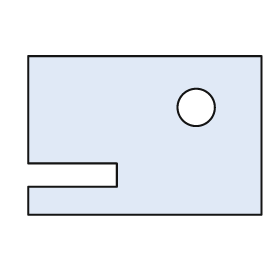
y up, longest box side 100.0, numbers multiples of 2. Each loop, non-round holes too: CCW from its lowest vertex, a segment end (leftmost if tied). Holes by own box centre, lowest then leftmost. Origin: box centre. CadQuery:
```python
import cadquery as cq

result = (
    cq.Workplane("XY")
    .moveTo(-50.0, -34.0)
    .lineTo(50.0, -34.0)
    .lineTo(50.0, 34.0)
    .lineTo(-50.0, 34.0)
    .lineTo(-50.0, -12.0)
    .lineTo(-12.0, -12.0)
    .lineTo(-12.0, -22.0)
    .lineTo(-50.0, -22.0)
    .close()
    .moveTo(22.0, 12.0)
    .circle(8.0)
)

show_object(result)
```